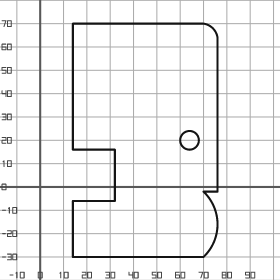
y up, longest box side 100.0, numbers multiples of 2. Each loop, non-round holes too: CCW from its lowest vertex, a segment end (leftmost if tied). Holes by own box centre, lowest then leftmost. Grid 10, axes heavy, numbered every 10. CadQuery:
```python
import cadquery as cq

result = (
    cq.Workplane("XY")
    .moveTo(14.0, -30.0)
    .lineTo(70.0, -30.0)
    .threePointArc((76.0, -16.0), (70.0, -2.0))
    .lineTo(76.0, -2.0)
    .lineTo(76.0, 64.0)
    .threePointArc((74.0, 68.0), (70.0, 70.0))
    .lineTo(14.0, 70.0)
    .lineTo(14.0, 16.0)
    .lineTo(32.0, 16.0)
    .lineTo(32.0, -6.0)
    .lineTo(14.0, -6.0)
    .close()
    .moveTo(64.0, 20.0)
    .circle(4.0)
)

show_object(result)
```